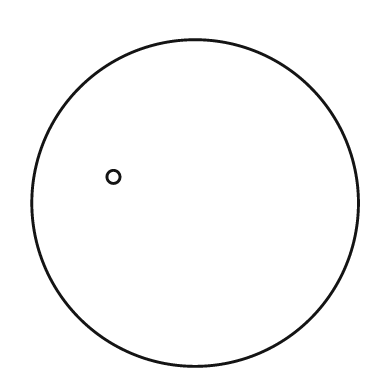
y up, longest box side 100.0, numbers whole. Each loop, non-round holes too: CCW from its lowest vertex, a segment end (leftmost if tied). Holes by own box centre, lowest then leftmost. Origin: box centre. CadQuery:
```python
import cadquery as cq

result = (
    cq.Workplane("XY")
    .moveTo(0.0, 0.0)
    .circle(50.0)
    .moveTo(-25.0, 8.0)
    .circle(2.0)
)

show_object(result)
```